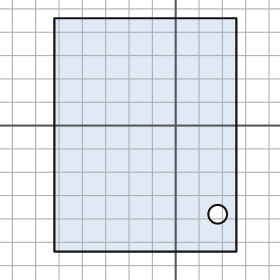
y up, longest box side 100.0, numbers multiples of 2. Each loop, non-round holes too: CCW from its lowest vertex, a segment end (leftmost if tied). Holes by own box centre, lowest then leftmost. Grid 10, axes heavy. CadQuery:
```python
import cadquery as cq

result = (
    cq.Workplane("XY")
    .moveTo(-52.0, -54.0)
    .lineTo(26.0, -54.0)
    .lineTo(26.0, 46.0)
    .lineTo(-52.0, 46.0)
    .close()
    .moveTo(18.0, -38.0)
    .circle(4.0)
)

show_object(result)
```